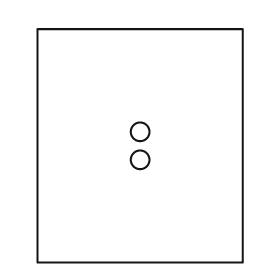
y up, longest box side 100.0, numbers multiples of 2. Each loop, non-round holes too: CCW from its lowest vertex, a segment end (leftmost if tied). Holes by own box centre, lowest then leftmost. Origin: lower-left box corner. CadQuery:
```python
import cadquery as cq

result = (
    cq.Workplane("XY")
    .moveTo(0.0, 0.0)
    .lineTo(88.0, 0.0)
    .lineTo(88.0, 100.0)
    .lineTo(0.0, 100.0)
    .close()
    .moveTo(44.0, 44.0)
    .circle(4.0)
    .moveTo(44.0, 56.0)
    .circle(4.0)
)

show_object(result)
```